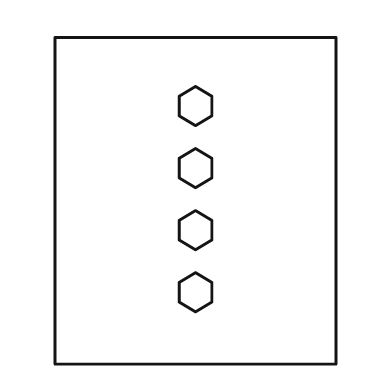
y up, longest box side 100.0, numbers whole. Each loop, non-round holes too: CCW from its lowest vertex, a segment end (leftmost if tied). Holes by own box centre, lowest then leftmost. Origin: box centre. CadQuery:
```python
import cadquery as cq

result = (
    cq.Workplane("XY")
    .moveTo(-43.0, -50.0)
    .lineTo(43.0, -50.0)
    .lineTo(43.0, 50.0)
    .lineTo(-43.0, 50.0)
    .close()
    .moveTo(0.0, -34.0)
    .lineTo(5.0, -31.0)
    .lineTo(5.0, -25.0)
    .lineTo(0.0, -22.0)
    .lineTo(-5.0, -25.0)
    .lineTo(-5.0, -31.0)
    .close()
    .moveTo(0.0, -15.0)
    .lineTo(5.0, -12.0)
    .lineTo(5.0, -6.0)
    .lineTo(0.0, -3.0)
    .lineTo(-5.0, -6.0)
    .lineTo(-5.0, -12.0)
    .close()
    .moveTo(0.0, 4.0)
    .lineTo(5.0, 7.0)
    .lineTo(5.0, 13.0)
    .lineTo(0.0, 16.0)
    .lineTo(-5.0, 13.0)
    .lineTo(-5.0, 7.0)
    .close()
    .moveTo(0.0, 23.0)
    .lineTo(5.0, 26.0)
    .lineTo(5.0, 32.0)
    .lineTo(0.0, 35.0)
    .lineTo(-5.0, 32.0)
    .lineTo(-5.0, 26.0)
    .close()
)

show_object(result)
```